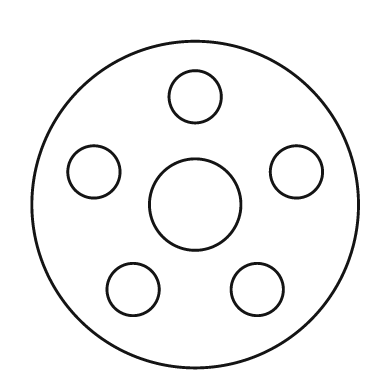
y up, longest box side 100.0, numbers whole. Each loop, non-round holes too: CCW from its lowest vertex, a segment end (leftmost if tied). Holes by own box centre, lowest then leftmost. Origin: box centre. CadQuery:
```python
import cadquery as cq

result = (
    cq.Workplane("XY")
    .moveTo(0.0, 0.0)
    .circle(50.0)
    .moveTo(-19.0, -26.0)
    .circle(8.0)
    .moveTo(19.0, -26.0)
    .circle(8.0)
    .moveTo(0.0, 0.0)
    .circle(14.0)
    .moveTo(-31.0, 10.0)
    .circle(8.0)
    .moveTo(31.0, 10.0)
    .circle(8.0)
    .moveTo(0.0, 33.0)
    .circle(8.0)
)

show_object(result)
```